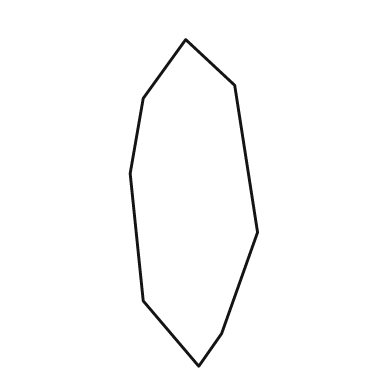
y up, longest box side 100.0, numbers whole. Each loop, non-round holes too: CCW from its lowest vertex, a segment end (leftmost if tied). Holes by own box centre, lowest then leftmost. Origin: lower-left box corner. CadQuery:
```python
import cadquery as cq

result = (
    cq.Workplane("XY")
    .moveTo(21.0, 0.0)
    .lineTo(28.0, 10.0)
    .lineTo(39.0, 41.0)
    .lineTo(32.0, 86.0)
    .lineTo(17.0, 100.0)
    .lineTo(4.0, 82.0)
    .lineTo(0.0, 59.0)
    .lineTo(4.0, 20.0)
    .close()
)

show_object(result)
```